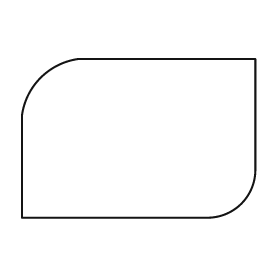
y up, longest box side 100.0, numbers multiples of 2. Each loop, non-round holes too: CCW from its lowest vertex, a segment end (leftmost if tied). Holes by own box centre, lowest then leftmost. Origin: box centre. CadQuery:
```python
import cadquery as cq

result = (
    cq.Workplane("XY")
    .moveTo(-50.0, -34.0)
    .lineTo(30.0, -34.0)
    .threePointArc((44.0, -28.0), (50.0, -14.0))
    .lineTo(50.0, 34.0)
    .lineTo(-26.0, 34.0)
    .threePointArc((-42.0, 26.0), (-50.0, 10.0))
    .close()
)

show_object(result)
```